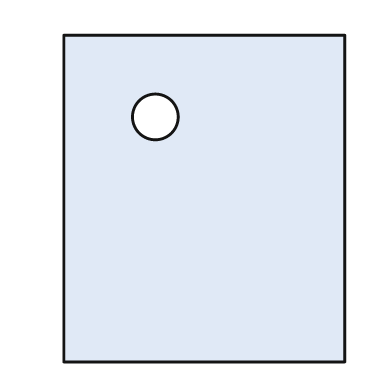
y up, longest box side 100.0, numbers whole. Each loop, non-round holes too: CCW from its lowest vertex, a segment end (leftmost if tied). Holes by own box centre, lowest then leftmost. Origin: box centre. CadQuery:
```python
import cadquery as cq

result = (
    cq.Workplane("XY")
    .moveTo(-43.0, -50.0)
    .lineTo(43.0, -50.0)
    .lineTo(43.0, 50.0)
    .lineTo(-43.0, 50.0)
    .close()
    .moveTo(-15.0, 25.0)
    .circle(7.0)
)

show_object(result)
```